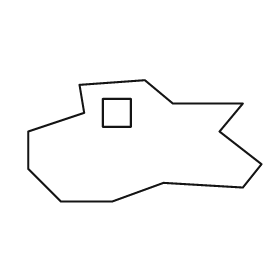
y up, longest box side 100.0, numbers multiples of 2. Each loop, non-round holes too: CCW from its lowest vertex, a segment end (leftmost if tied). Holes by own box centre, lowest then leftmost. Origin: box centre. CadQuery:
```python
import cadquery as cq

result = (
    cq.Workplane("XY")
    .moveTo(-36.0, -26.0)
    .lineTo(-14.0, -26.0)
    .lineTo(8.0, -18.0)
    .lineTo(42.0, -20.0)
    .lineTo(50.0, -10.0)
    .lineTo(32.0, 4.0)
    .lineTo(42.0, 16.0)
    .lineTo(12.0, 16.0)
    .lineTo(0.0, 26.0)
    .lineTo(-28.0, 24.0)
    .lineTo(-26.0, 12.0)
    .lineTo(-50.0, 4.0)
    .lineTo(-50.0, -12.0)
    .close()
    .moveTo(-18.0, 6.0)
    .lineTo(-6.0, 6.0)
    .lineTo(-6.0, 18.0)
    .lineTo(-18.0, 18.0)
    .close()
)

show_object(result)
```